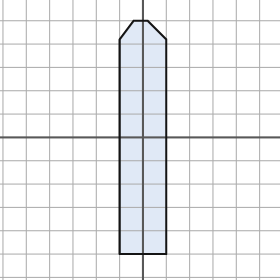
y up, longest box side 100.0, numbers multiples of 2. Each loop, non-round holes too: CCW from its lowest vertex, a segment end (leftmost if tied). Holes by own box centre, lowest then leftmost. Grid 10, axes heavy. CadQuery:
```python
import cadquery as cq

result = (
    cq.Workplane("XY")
    .moveTo(-10.0, -50.0)
    .lineTo(10.0, -50.0)
    .lineTo(10.0, 42.0)
    .lineTo(2.0, 50.0)
    .lineTo(-4.0, 50.0)
    .lineTo(-10.0, 42.0)
    .close()
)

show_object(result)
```